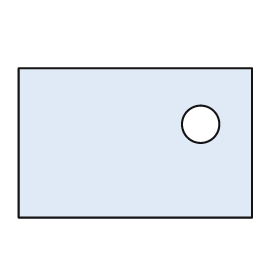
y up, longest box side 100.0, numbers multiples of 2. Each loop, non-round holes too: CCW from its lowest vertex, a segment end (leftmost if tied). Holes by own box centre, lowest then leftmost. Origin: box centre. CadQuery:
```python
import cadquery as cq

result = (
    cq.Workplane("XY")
    .moveTo(-50.0, -32.0)
    .lineTo(50.0, -32.0)
    .lineTo(50.0, 32.0)
    .lineTo(-50.0, 32.0)
    .close()
    .moveTo(28.0, 8.0)
    .circle(8.0)
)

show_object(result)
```